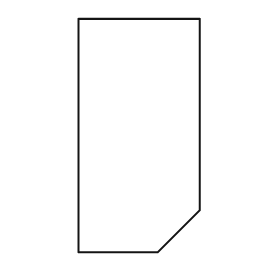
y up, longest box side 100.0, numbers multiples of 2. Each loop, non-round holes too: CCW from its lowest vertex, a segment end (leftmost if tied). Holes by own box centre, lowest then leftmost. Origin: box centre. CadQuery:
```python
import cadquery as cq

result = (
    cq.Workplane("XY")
    .moveTo(-26.0, -50.0)
    .lineTo(8.0, -50.0)
    .lineTo(26.0, -32.0)
    .lineTo(26.0, 50.0)
    .lineTo(-26.0, 50.0)
    .close()
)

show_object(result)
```